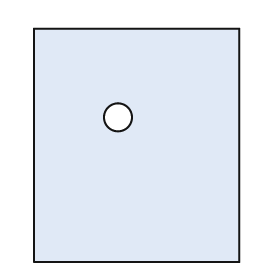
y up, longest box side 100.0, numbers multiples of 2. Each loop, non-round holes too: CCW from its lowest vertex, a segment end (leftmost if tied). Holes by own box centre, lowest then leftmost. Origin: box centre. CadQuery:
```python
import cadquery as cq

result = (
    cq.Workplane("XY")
    .moveTo(-44.0, -50.0)
    .lineTo(44.0, -50.0)
    .lineTo(44.0, 50.0)
    .lineTo(-44.0, 50.0)
    .close()
    .moveTo(-8.0, 12.0)
    .circle(6.0)
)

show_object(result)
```